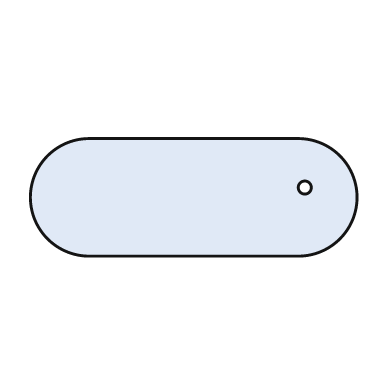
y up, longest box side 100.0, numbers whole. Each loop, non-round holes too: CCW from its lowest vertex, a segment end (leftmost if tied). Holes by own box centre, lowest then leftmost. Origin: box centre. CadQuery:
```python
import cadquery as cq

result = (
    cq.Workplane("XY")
    .moveTo(-32.0, -18.0)
    .lineTo(32.0, -18.0)
    .threePointArc((50.0, 0.0), (32.0, 18.0))
    .lineTo(-32.0, 18.0)
    .threePointArc((-50.0, 0.0), (-32.0, -18.0))
    .close()
    .moveTo(34.0, 3.0)
    .circle(2.0)
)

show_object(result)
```